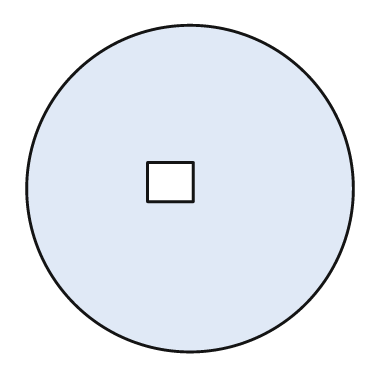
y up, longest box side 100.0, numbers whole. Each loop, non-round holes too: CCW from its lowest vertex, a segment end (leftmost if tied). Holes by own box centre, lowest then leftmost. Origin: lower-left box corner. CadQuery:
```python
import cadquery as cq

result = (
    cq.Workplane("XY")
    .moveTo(50.0, 50.0)
    .circle(50.0)
    .moveTo(37.0, 46.0)
    .lineTo(51.0, 46.0)
    .lineTo(51.0, 58.0)
    .lineTo(37.0, 58.0)
    .close()
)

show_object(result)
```